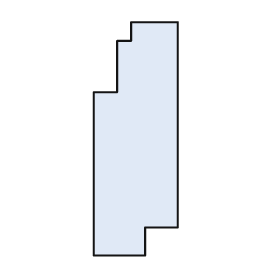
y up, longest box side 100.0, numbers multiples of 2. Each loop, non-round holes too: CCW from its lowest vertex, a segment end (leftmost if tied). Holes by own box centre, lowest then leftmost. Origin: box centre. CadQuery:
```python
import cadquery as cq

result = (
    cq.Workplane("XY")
    .moveTo(-18.0, -50.0)
    .lineTo(4.0, -50.0)
    .lineTo(4.0, -38.0)
    .lineTo(18.0, -38.0)
    .lineTo(18.0, 50.0)
    .lineTo(-2.0, 50.0)
    .lineTo(-2.0, 42.0)
    .lineTo(-8.0, 42.0)
    .lineTo(-8.0, 20.0)
    .lineTo(-18.0, 20.0)
    .close()
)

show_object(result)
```